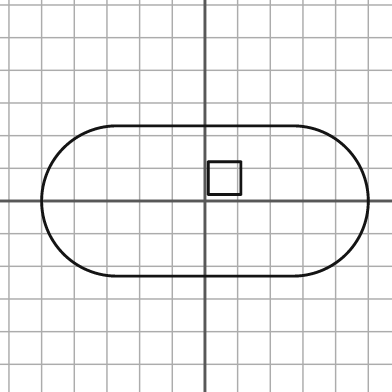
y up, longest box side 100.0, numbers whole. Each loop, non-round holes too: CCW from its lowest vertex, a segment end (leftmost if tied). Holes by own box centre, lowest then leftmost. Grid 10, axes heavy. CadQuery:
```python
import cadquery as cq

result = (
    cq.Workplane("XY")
    .moveTo(-27.0, -23.0)
    .lineTo(27.0, -23.0)
    .threePointArc((50.0, 0.0), (27.0, 23.0))
    .lineTo(-27.0, 23.0)
    .threePointArc((-50.0, 0.0), (-27.0, -23.0))
    .close()
    .moveTo(1.0, 2.0)
    .lineTo(11.0, 2.0)
    .lineTo(11.0, 12.0)
    .lineTo(1.0, 12.0)
    .close()
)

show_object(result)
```